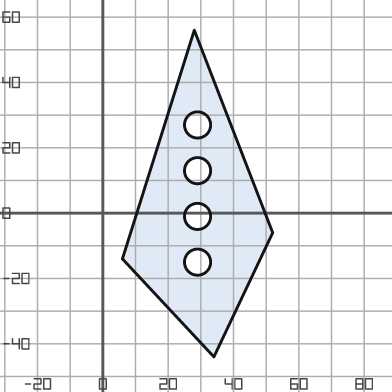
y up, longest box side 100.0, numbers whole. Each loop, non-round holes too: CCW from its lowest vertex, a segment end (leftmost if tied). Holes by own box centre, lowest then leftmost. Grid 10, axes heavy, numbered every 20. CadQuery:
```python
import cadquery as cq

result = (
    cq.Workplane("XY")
    .moveTo(34.0, -44.0)
    .lineTo(52.0, -6.0)
    .lineTo(28.0, 56.0)
    .lineTo(6.0, -14.0)
    .close()
    .moveTo(29.0, -15.0)
    .circle(4.0)
    .moveTo(29.0, -1.0)
    .circle(4.0)
    .moveTo(29.0, 13.0)
    .circle(4.0)
    .moveTo(29.0, 27.0)
    .circle(4.0)
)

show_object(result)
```